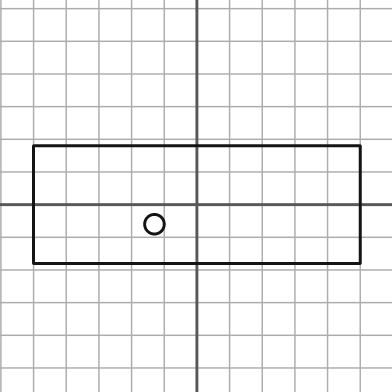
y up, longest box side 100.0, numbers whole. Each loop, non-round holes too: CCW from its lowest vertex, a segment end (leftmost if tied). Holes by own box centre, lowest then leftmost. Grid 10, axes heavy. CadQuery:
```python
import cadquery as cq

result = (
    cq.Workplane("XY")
    .moveTo(-50.0, -18.0)
    .lineTo(50.0, -18.0)
    .lineTo(50.0, 18.0)
    .lineTo(-50.0, 18.0)
    .close()
    .moveTo(-13.0, -6.0)
    .circle(3.0)
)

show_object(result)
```